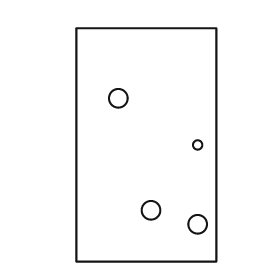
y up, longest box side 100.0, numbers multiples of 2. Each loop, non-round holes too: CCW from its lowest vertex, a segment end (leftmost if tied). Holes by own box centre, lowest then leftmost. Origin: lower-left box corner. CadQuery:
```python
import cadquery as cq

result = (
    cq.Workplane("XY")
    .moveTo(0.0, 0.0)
    .lineTo(60.0, 0.0)
    .lineTo(60.0, 100.0)
    .lineTo(0.0, 100.0)
    .close()
    .moveTo(52.0, 16.0)
    .circle(4.0)
    .moveTo(32.0, 22.0)
    .circle(4.0)
    .moveTo(52.0, 50.0)
    .circle(2.0)
    .moveTo(18.0, 70.0)
    .circle(4.0)
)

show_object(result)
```